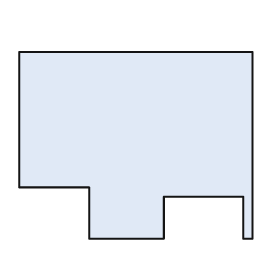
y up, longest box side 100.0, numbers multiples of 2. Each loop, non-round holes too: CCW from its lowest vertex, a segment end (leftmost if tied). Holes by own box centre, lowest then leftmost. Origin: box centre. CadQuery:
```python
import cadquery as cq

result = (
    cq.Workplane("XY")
    .moveTo(-20.0, -40.0)
    .lineTo(12.0, -40.0)
    .lineTo(12.0, -22.0)
    .lineTo(46.0, -22.0)
    .lineTo(46.0, -40.0)
    .lineTo(50.0, -40.0)
    .lineTo(50.0, 40.0)
    .lineTo(-50.0, 40.0)
    .lineTo(-50.0, -18.0)
    .lineTo(-20.0, -18.0)
    .close()
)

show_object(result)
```